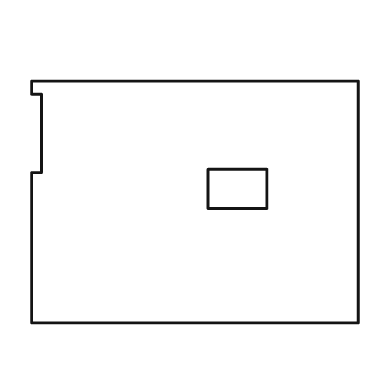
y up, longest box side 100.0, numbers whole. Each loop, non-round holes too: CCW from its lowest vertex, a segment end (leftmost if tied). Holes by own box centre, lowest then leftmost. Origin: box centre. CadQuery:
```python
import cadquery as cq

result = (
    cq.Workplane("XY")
    .moveTo(-50.0, -37.0)
    .lineTo(50.0, -37.0)
    .lineTo(50.0, 37.0)
    .lineTo(-50.0, 37.0)
    .lineTo(-50.0, 33.0)
    .lineTo(-47.0, 33.0)
    .lineTo(-47.0, 9.0)
    .lineTo(-50.0, 9.0)
    .close()
    .moveTo(4.0, -2.0)
    .lineTo(22.0, -2.0)
    .lineTo(22.0, 10.0)
    .lineTo(4.0, 10.0)
    .close()
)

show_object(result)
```